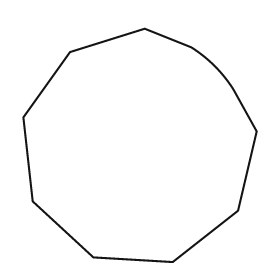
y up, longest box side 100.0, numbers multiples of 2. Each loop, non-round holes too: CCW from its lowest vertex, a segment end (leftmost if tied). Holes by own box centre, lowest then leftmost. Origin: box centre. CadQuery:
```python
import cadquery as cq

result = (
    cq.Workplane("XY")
    .moveTo(14.0, -50.0)
    .lineTo(42.0, -28.0)
    .lineTo(50.0, 6.0)
    .lineTo(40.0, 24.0)
    .threePointArc((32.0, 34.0), (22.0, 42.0))
    .lineTo(2.0, 50.0)
    .lineTo(-30.0, 40.0)
    .lineTo(-50.0, 12.0)
    .lineTo(-46.0, -24.0)
    .lineTo(-20.0, -48.0)
    .close()
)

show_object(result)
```